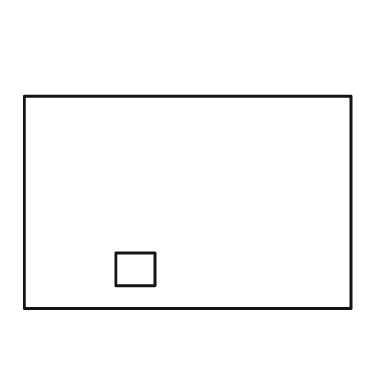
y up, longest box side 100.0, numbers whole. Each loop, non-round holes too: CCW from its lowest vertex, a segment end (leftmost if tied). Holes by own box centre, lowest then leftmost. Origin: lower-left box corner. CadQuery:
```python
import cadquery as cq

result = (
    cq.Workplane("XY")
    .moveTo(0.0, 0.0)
    .lineTo(100.0, 0.0)
    .lineTo(100.0, 65.0)
    .lineTo(0.0, 65.0)
    .close()
    .moveTo(28.0, 7.0)
    .lineTo(40.0, 7.0)
    .lineTo(40.0, 17.0)
    .lineTo(28.0, 17.0)
    .close()
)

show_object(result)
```